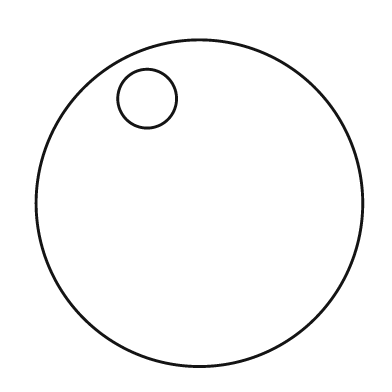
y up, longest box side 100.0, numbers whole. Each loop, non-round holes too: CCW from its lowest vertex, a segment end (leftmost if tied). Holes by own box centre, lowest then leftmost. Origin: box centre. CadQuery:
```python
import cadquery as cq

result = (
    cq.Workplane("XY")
    .moveTo(0.0, 0.0)
    .circle(50.0)
    .moveTo(-16.0, 32.0)
    .circle(9.0)
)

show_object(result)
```